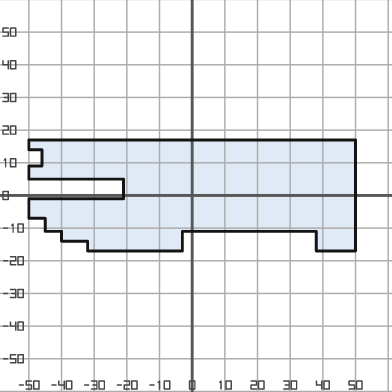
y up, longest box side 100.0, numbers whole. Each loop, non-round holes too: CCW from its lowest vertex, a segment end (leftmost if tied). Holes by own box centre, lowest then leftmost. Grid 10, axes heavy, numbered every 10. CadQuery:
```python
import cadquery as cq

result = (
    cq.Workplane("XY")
    .moveTo(-32.0, -17.0)
    .lineTo(-3.0, -17.0)
    .lineTo(-3.0, -11.0)
    .lineTo(38.0, -11.0)
    .lineTo(38.0, -17.0)
    .lineTo(50.0, -17.0)
    .lineTo(50.0, 17.0)
    .lineTo(-50.0, 17.0)
    .lineTo(-50.0, 14.0)
    .lineTo(-46.0, 14.0)
    .lineTo(-46.0, 9.0)
    .lineTo(-50.0, 9.0)
    .lineTo(-50.0, 5.0)
    .lineTo(-21.0, 5.0)
    .lineTo(-21.0, -1.0)
    .lineTo(-50.0, -1.0)
    .lineTo(-50.0, -7.0)
    .lineTo(-45.0, -7.0)
    .lineTo(-45.0, -11.0)
    .lineTo(-40.0, -11.0)
    .lineTo(-40.0, -14.0)
    .lineTo(-32.0, -14.0)
    .close()
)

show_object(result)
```